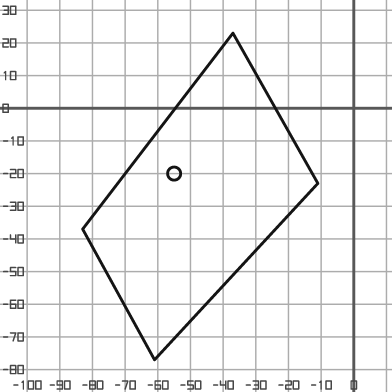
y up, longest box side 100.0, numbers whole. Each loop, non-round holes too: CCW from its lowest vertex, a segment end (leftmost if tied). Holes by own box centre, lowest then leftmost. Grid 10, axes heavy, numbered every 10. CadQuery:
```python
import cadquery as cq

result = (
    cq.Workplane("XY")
    .moveTo(-61.0, -77.0)
    .lineTo(-11.0, -23.0)
    .lineTo(-37.0, 23.0)
    .lineTo(-83.0, -37.0)
    .close()
    .moveTo(-55.0, -20.0)
    .circle(2.0)
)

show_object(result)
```